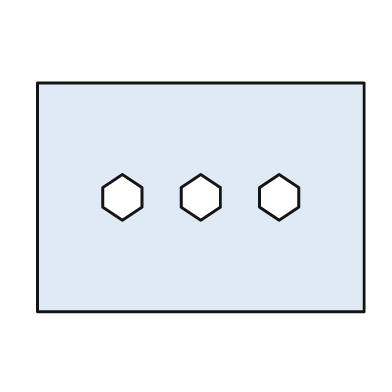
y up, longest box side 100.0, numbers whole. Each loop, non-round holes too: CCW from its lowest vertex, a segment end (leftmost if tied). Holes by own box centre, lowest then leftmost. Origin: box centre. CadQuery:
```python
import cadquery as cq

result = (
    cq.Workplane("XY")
    .moveTo(-50.0, -35.0)
    .lineTo(50.0, -35.0)
    .lineTo(50.0, 35.0)
    .lineTo(-50.0, 35.0)
    .close()
    .moveTo(-24.0, -7.0)
    .lineTo(-18.0, -3.0)
    .lineTo(-18.0, 3.0)
    .lineTo(-24.0, 7.0)
    .lineTo(-30.0, 3.0)
    .lineTo(-30.0, -3.0)
    .close()
    .moveTo(0.0, -7.0)
    .lineTo(6.0, -3.0)
    .lineTo(6.0, 3.0)
    .lineTo(0.0, 7.0)
    .lineTo(-6.0, 3.0)
    .lineTo(-6.0, -3.0)
    .close()
    .moveTo(24.0, -7.0)
    .lineTo(30.0, -3.0)
    .lineTo(30.0, 3.0)
    .lineTo(24.0, 7.0)
    .lineTo(18.0, 3.0)
    .lineTo(18.0, -3.0)
    .close()
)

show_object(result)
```